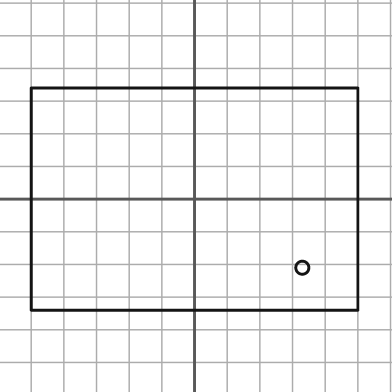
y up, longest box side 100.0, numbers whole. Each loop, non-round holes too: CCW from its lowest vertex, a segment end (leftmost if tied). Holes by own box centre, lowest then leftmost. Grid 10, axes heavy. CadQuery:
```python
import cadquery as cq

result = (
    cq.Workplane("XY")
    .moveTo(-50.0, -34.0)
    .lineTo(50.0, -34.0)
    .lineTo(50.0, 34.0)
    .lineTo(-50.0, 34.0)
    .close()
    .moveTo(33.0, -21.0)
    .circle(2.0)
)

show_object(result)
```